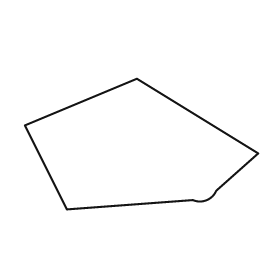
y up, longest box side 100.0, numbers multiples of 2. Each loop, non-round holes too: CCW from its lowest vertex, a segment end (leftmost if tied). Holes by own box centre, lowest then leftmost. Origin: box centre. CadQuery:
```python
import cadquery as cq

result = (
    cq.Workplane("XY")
    .moveTo(-32.0, -28.0)
    .lineTo(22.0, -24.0)
    .threePointArc((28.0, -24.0), (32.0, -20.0))
    .lineTo(50.0, -4.0)
    .lineTo(-2.0, 28.0)
    .lineTo(-50.0, 8.0)
    .close()
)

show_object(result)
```